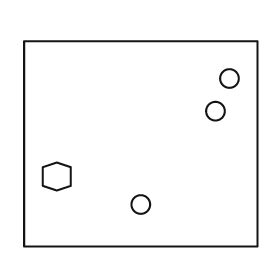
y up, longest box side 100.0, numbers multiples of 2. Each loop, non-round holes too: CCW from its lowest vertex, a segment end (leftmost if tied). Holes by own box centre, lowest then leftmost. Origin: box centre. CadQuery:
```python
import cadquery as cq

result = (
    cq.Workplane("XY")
    .moveTo(-50.0, -44.0)
    .lineTo(50.0, -44.0)
    .lineTo(50.0, 44.0)
    .lineTo(-50.0, 44.0)
    .close()
    .moveTo(0.0, -26.0)
    .circle(4.0)
    .moveTo(-36.0, -20.0)
    .lineTo(-30.0, -18.0)
    .lineTo(-30.0, -10.0)
    .lineTo(-36.0, -8.0)
    .lineTo(-42.0, -10.0)
    .lineTo(-42.0, -18.0)
    .close()
    .moveTo(32.0, 14.0)
    .circle(4.0)
    .moveTo(38.0, 28.0)
    .circle(4.0)
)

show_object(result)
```